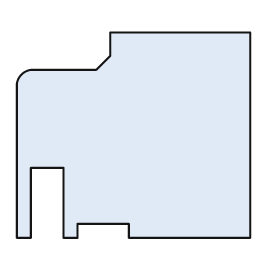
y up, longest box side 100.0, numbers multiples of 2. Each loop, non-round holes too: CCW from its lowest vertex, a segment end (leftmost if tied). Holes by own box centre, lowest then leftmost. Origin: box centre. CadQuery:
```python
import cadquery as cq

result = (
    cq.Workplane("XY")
    .moveTo(-50.0, -44.0)
    .lineTo(-44.0, -44.0)
    .lineTo(-44.0, -14.0)
    .lineTo(-30.0, -14.0)
    .lineTo(-30.0, -44.0)
    .lineTo(-24.0, -44.0)
    .lineTo(-24.0, -38.0)
    .lineTo(-2.0, -38.0)
    .lineTo(-2.0, -44.0)
    .lineTo(50.0, -44.0)
    .lineTo(50.0, 44.0)
    .lineTo(-10.0, 44.0)
    .lineTo(-10.0, 34.0)
    .lineTo(-16.0, 28.0)
    .lineTo(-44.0, 28.0)
    .threePointArc((-48.0, 26.0), (-50.0, 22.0))
    .close()
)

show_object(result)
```